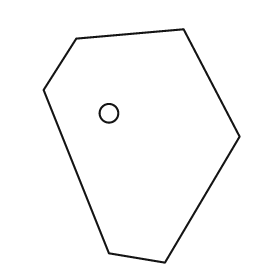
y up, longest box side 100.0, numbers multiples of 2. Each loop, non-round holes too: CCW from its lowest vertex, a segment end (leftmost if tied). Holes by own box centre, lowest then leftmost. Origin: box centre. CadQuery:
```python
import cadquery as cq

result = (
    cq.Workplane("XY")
    .moveTo(10.0, -50.0)
    .lineTo(42.0, 4.0)
    .lineTo(18.0, 50.0)
    .lineTo(-28.0, 46.0)
    .lineTo(-42.0, 24.0)
    .lineTo(-14.0, -46.0)
    .close()
    .moveTo(-14.0, 14.0)
    .circle(4.0)
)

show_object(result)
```